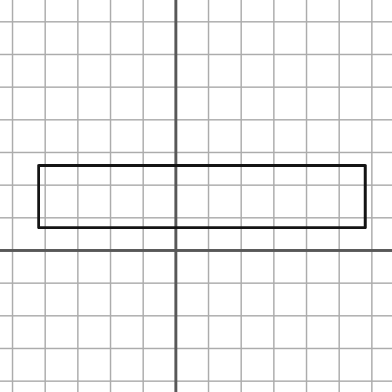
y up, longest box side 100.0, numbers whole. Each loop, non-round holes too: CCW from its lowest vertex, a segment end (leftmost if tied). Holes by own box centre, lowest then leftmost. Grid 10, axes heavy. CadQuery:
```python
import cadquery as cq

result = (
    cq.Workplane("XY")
    .moveTo(-42.0, 7.0)
    .lineTo(58.0, 7.0)
    .lineTo(58.0, 26.0)
    .lineTo(-42.0, 26.0)
    .close()
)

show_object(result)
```